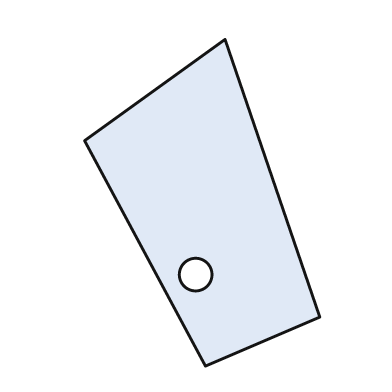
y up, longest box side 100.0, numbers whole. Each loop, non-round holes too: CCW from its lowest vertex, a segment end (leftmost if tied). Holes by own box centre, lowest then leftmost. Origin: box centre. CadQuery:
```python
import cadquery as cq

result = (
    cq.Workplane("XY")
    .moveTo(1.0, -50.0)
    .lineTo(36.0, -35.0)
    .lineTo(7.0, 50.0)
    .lineTo(-36.0, 19.0)
    .close()
    .moveTo(-2.0, -22.0)
    .circle(5.0)
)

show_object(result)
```